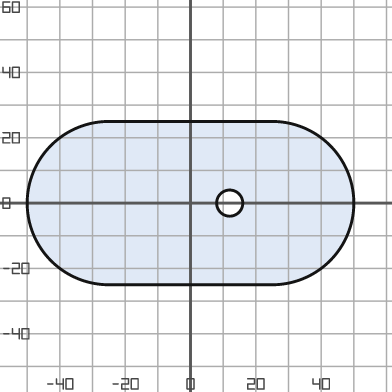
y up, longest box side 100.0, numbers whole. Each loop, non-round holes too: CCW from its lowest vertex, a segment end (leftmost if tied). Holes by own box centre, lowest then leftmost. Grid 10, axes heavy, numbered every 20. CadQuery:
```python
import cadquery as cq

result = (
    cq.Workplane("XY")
    .moveTo(-25.0, -25.0)
    .lineTo(25.0, -25.0)
    .threePointArc((50.0, 0.0), (25.0, 25.0))
    .lineTo(-25.0, 25.0)
    .threePointArc((-50.0, 0.0), (-25.0, -25.0))
    .close()
    .moveTo(12.0, 0.0)
    .circle(4.0)
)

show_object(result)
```